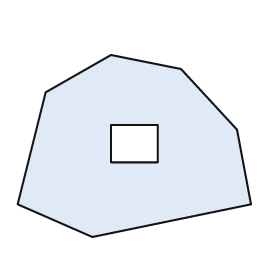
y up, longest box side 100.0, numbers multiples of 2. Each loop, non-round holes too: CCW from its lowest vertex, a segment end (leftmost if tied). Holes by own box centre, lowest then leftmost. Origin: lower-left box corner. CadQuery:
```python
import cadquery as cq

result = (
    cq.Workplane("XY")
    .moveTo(32.0, 0.0)
    .lineTo(100.0, 14.0)
    .lineTo(94.0, 46.0)
    .lineTo(70.0, 72.0)
    .lineTo(40.0, 78.0)
    .lineTo(12.0, 62.0)
    .lineTo(0.0, 14.0)
    .close()
    .moveTo(40.0, 32.0)
    .lineTo(60.0, 32.0)
    .lineTo(60.0, 48.0)
    .lineTo(40.0, 48.0)
    .close()
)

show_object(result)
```